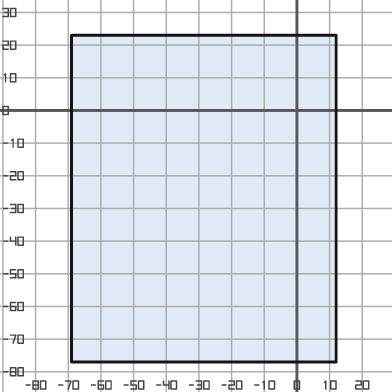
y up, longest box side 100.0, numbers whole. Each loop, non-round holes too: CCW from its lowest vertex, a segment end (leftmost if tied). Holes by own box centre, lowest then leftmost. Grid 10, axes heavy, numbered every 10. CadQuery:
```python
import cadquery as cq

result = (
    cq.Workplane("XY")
    .moveTo(-69.0, -77.0)
    .lineTo(12.0, -77.0)
    .lineTo(12.0, 23.0)
    .lineTo(-69.0, 23.0)
    .close()
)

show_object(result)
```